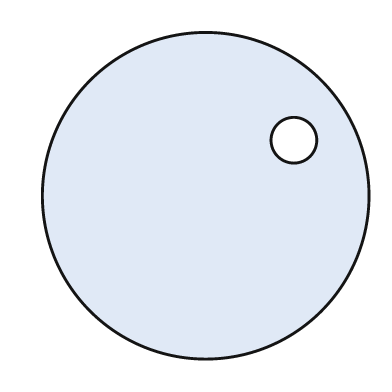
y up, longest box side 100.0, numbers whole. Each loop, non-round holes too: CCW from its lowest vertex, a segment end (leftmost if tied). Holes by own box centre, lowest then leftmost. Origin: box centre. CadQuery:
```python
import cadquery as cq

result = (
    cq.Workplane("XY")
    .moveTo(0.0, 0.0)
    .circle(50.0)
    .moveTo(27.0, 17.0)
    .circle(7.0)
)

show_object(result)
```